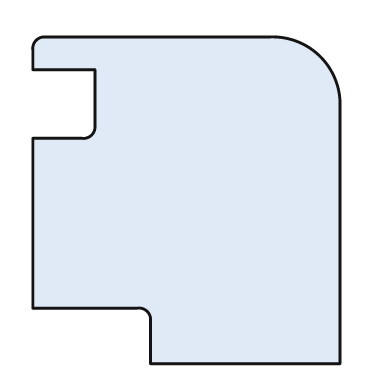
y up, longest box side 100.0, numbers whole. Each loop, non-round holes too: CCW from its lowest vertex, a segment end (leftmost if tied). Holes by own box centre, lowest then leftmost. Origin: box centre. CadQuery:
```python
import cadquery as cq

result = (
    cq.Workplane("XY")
    .moveTo(-11.0, -50.0)
    .lineTo(47.0, -50.0)
    .lineTo(47.0, 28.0)
    .threePointArc((41.0, 44.0), (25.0, 50.0))
    .lineTo(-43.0, 50.0)
    .threePointArc((-46.0, 49.0), (-47.0, 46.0))
    .lineTo(-47.0, 40.0)
    .lineTo(-28.0, 40.0)
    .lineTo(-28.0, 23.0)
    .threePointArc((-29.0, 20.0), (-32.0, 19.0))
    .lineTo(-47.0, 19.0)
    .lineTo(-47.0, -33.0)
    .lineTo(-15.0, -33.0)
    .threePointArc((-12.0, -34.0), (-11.0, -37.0))
    .close()
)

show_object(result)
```